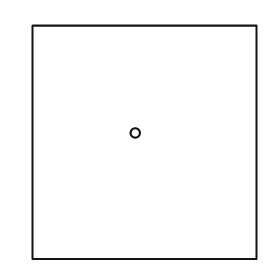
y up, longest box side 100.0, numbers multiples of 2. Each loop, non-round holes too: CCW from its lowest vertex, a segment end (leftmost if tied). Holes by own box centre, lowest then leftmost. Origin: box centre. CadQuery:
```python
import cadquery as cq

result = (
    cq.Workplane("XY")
    .moveTo(-48.0, -50.0)
    .lineTo(48.0, -50.0)
    .lineTo(48.0, 50.0)
    .lineTo(-48.0, 50.0)
    .close()
    .moveTo(-4.0, 4.0)
    .circle(2.0)
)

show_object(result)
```